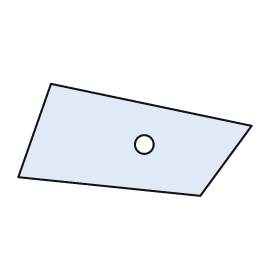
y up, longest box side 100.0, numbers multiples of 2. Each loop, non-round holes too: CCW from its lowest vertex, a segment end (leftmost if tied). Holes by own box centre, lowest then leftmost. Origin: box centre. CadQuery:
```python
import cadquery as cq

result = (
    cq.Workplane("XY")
    .moveTo(28.0, -24.0)
    .lineTo(50.0, 6.0)
    .lineTo(-36.0, 24.0)
    .lineTo(-50.0, -16.0)
    .close()
    .moveTo(4.0, -2.0)
    .circle(4.0)
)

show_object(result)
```